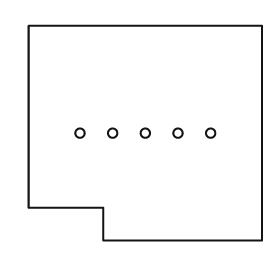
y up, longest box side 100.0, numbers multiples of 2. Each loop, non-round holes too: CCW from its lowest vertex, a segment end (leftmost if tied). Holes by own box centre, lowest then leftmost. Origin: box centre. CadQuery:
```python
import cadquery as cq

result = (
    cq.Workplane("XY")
    .moveTo(-18.0, -46.0)
    .lineTo(50.0, -46.0)
    .lineTo(50.0, 46.0)
    .lineTo(-50.0, 46.0)
    .lineTo(-50.0, -32.0)
    .lineTo(-18.0, -32.0)
    .close()
    .moveTo(-28.0, 0.0)
    .circle(2.0)
    .moveTo(-14.0, 0.0)
    .circle(2.0)
    .moveTo(0.0, 0.0)
    .circle(2.0)
    .moveTo(14.0, 0.0)
    .circle(2.0)
    .moveTo(28.0, 0.0)
    .circle(2.0)
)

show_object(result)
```